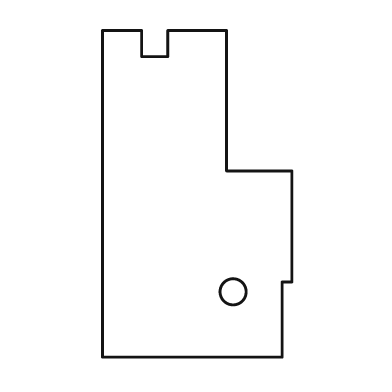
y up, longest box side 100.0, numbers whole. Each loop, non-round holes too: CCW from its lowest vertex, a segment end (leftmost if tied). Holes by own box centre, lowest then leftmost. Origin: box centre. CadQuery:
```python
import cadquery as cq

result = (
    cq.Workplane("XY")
    .moveTo(-29.0, -50.0)
    .lineTo(26.0, -50.0)
    .lineTo(26.0, -27.0)
    .lineTo(29.0, -27.0)
    .lineTo(29.0, 7.0)
    .lineTo(9.0, 7.0)
    .lineTo(9.0, 50.0)
    .lineTo(-9.0, 50.0)
    .lineTo(-9.0, 42.0)
    .lineTo(-17.0, 42.0)
    .lineTo(-17.0, 50.0)
    .lineTo(-29.0, 50.0)
    .close()
    .moveTo(11.0, -30.0)
    .circle(4.0)
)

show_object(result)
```